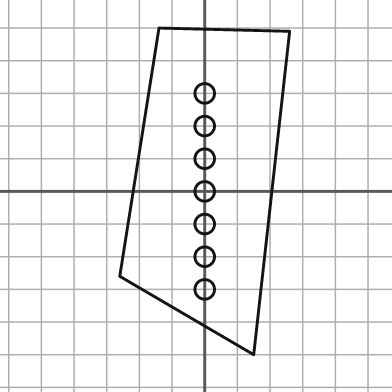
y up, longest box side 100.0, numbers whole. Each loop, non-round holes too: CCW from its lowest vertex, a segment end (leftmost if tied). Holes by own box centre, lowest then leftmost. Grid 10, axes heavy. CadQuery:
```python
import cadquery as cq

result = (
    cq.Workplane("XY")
    .moveTo(15.0, -50.0)
    .lineTo(26.0, 49.0)
    .lineTo(-14.0, 50.0)
    .lineTo(-26.0, -26.0)
    .close()
    .moveTo(0.0, -30.0)
    .circle(3.0)
    .moveTo(0.0, -20.0)
    .circle(3.0)
    .moveTo(0.0, -10.0)
    .circle(3.0)
    .moveTo(0.0, 0.0)
    .circle(3.0)
    .moveTo(0.0, 10.0)
    .circle(3.0)
    .moveTo(0.0, 20.0)
    .circle(3.0)
    .moveTo(0.0, 30.0)
    .circle(3.0)
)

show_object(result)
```